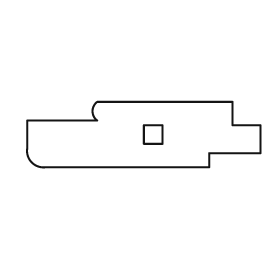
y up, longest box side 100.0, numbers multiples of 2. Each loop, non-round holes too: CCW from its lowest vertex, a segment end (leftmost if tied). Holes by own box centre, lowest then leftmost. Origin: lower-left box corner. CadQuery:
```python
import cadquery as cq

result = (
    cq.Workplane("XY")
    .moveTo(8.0, 0.0)
    .lineTo(78.0, 0.0)
    .lineTo(78.0, 6.0)
    .lineTo(100.0, 6.0)
    .lineTo(100.0, 18.0)
    .lineTo(88.0, 18.0)
    .lineTo(88.0, 28.0)
    .lineTo(30.0, 28.0)
    .threePointArc((28.0, 24.0), (30.0, 20.0))
    .lineTo(0.0, 20.0)
    .lineTo(0.0, 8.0)
    .threePointArc((2.0, 2.0), (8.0, 0.0))
    .close()
    .moveTo(50.0, 10.0)
    .lineTo(58.0, 10.0)
    .lineTo(58.0, 18.0)
    .lineTo(50.0, 18.0)
    .close()
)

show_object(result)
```